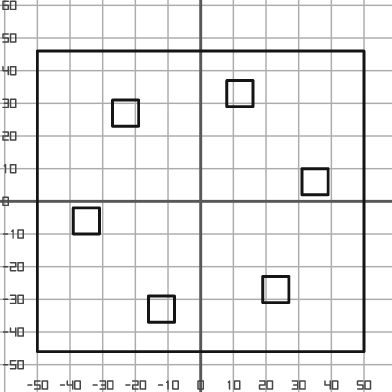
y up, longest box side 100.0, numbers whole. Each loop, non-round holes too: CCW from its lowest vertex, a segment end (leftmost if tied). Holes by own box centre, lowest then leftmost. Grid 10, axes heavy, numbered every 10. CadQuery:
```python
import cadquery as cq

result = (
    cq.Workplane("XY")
    .moveTo(-50.0, -46.0)
    .lineTo(50.0, -46.0)
    .lineTo(50.0, 46.0)
    .lineTo(-50.0, 46.0)
    .close()
    .moveTo(-16.0, -37.0)
    .lineTo(-8.0, -37.0)
    .lineTo(-8.0, -29.0)
    .lineTo(-16.0, -29.0)
    .close()
    .moveTo(19.0, -31.0)
    .lineTo(27.0, -31.0)
    .lineTo(27.0, -23.0)
    .lineTo(19.0, -23.0)
    .close()
    .moveTo(-39.0, -10.0)
    .lineTo(-31.0, -10.0)
    .lineTo(-31.0, -2.0)
    .lineTo(-39.0, -2.0)
    .close()
    .moveTo(31.0, 2.0)
    .lineTo(39.0, 2.0)
    .lineTo(39.0, 10.0)
    .lineTo(31.0, 10.0)
    .close()
    .moveTo(-27.0, 23.0)
    .lineTo(-19.0, 23.0)
    .lineTo(-19.0, 31.0)
    .lineTo(-27.0, 31.0)
    .close()
    .moveTo(8.0, 29.0)
    .lineTo(16.0, 29.0)
    .lineTo(16.0, 37.0)
    .lineTo(8.0, 37.0)
    .close()
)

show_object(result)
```